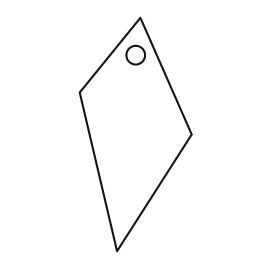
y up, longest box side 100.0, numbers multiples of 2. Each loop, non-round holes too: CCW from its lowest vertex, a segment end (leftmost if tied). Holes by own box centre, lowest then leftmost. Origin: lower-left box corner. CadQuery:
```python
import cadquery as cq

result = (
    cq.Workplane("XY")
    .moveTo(16.0, 0.0)
    .lineTo(48.0, 50.0)
    .lineTo(26.0, 100.0)
    .lineTo(0.0, 68.0)
    .close()
    .moveTo(24.0, 84.0)
    .circle(4.0)
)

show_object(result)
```